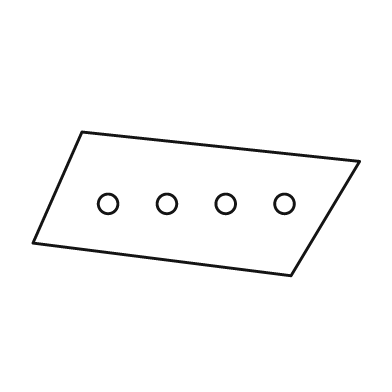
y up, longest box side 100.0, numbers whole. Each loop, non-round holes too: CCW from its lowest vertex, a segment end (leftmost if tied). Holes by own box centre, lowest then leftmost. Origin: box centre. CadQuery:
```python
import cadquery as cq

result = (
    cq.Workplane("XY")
    .moveTo(29.0, -22.0)
    .lineTo(50.0, 13.0)
    .lineTo(-35.0, 22.0)
    .lineTo(-50.0, -12.0)
    .close()
    .moveTo(-27.0, 0.0)
    .circle(3.0)
    .moveTo(-9.0, 0.0)
    .circle(3.0)
    .moveTo(9.0, 0.0)
    .circle(3.0)
    .moveTo(27.0, 0.0)
    .circle(3.0)
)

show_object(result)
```